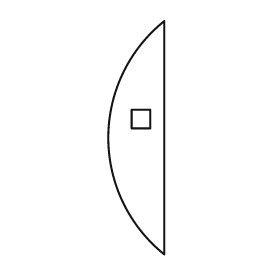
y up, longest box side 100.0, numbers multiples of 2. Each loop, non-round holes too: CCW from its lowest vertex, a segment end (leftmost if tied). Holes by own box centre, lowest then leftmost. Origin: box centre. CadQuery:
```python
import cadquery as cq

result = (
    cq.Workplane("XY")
    .moveTo(12.0, -50.0)
    .lineTo(12.0, 50.0)
    .threePointArc((-12.0, 0.0), (12.0, -50.0))
    .close()
    .moveTo(-2.0, 4.0)
    .lineTo(6.0, 4.0)
    .lineTo(6.0, 12.0)
    .lineTo(-2.0, 12.0)
    .close()
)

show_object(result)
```